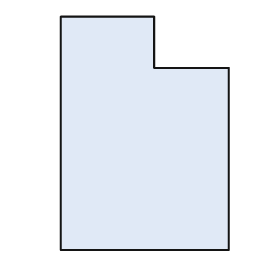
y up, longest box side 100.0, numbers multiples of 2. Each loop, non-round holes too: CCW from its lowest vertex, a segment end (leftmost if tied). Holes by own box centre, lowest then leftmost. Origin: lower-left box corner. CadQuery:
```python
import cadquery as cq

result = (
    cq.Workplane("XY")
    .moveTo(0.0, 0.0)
    .lineTo(72.0, 0.0)
    .lineTo(72.0, 78.0)
    .lineTo(40.0, 78.0)
    .lineTo(40.0, 100.0)
    .lineTo(0.0, 100.0)
    .close()
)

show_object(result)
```